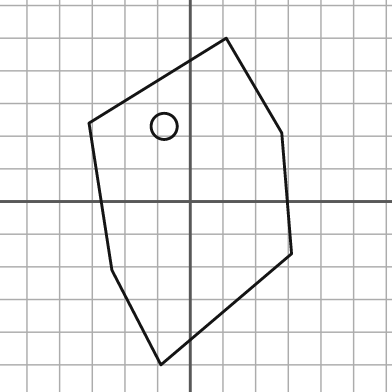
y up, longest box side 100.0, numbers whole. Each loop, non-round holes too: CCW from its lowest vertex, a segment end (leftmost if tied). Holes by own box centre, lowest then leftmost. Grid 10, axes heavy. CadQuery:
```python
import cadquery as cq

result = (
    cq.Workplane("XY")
    .moveTo(-9.0, -50.0)
    .lineTo(31.0, -16.0)
    .lineTo(28.0, 21.0)
    .lineTo(11.0, 50.0)
    .lineTo(-31.0, 24.0)
    .lineTo(-24.0, -21.0)
    .close()
    .moveTo(-8.0, 23.0)
    .circle(4.0)
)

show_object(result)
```